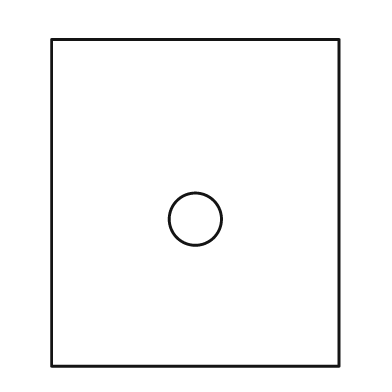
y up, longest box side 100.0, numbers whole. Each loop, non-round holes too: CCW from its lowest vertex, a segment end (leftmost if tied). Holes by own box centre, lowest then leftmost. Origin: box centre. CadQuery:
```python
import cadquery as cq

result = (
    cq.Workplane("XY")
    .moveTo(-44.0, -50.0)
    .lineTo(44.0, -50.0)
    .lineTo(44.0, 50.0)
    .lineTo(-44.0, 50.0)
    .close()
    .moveTo(0.0, -5.0)
    .circle(8.0)
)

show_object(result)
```